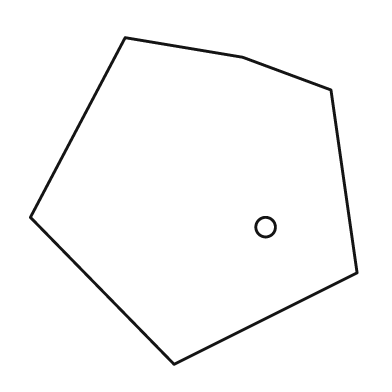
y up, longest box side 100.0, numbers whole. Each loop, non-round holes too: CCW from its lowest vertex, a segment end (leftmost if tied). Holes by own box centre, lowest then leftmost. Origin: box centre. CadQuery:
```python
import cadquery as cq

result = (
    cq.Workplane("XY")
    .moveTo(-6.0, -50.0)
    .lineTo(50.0, -22.0)
    .lineTo(42.0, 34.0)
    .lineTo(15.0, 44.0)
    .lineTo(-21.0, 50.0)
    .lineTo(-50.0, -5.0)
    .close()
    .moveTo(22.0, -8.0)
    .circle(3.0)
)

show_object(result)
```